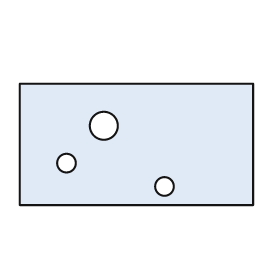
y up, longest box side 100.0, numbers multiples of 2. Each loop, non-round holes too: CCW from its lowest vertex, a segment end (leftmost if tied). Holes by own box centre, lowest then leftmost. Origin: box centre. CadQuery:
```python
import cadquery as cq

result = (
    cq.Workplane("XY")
    .moveTo(-50.0, -26.0)
    .lineTo(50.0, -26.0)
    .lineTo(50.0, 26.0)
    .lineTo(-50.0, 26.0)
    .close()
    .moveTo(12.0, -18.0)
    .circle(4.0)
    .moveTo(-30.0, -8.0)
    .circle(4.0)
    .moveTo(-14.0, 8.0)
    .circle(6.0)
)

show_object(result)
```